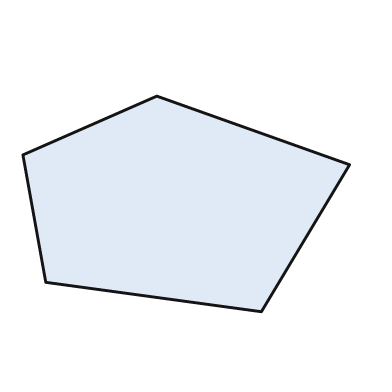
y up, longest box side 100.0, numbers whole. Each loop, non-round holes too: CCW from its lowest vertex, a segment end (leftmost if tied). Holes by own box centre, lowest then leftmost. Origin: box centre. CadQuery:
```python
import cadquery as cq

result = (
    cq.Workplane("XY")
    .moveTo(23.0, -33.0)
    .lineTo(50.0, 12.0)
    .lineTo(-9.0, 33.0)
    .lineTo(-50.0, 15.0)
    .lineTo(-43.0, -24.0)
    .close()
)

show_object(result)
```